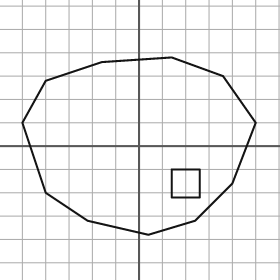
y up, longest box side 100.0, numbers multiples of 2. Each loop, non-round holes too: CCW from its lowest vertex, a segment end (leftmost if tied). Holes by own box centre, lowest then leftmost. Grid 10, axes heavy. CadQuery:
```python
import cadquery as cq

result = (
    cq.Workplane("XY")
    .moveTo(4.0, -38.0)
    .lineTo(24.0, -32.0)
    .lineTo(40.0, -16.0)
    .lineTo(50.0, 10.0)
    .lineTo(36.0, 30.0)
    .lineTo(14.0, 38.0)
    .lineTo(-16.0, 36.0)
    .lineTo(-40.0, 28.0)
    .lineTo(-50.0, 10.0)
    .lineTo(-40.0, -20.0)
    .lineTo(-22.0, -32.0)
    .close()
    .moveTo(14.0, -22.0)
    .lineTo(26.0, -22.0)
    .lineTo(26.0, -10.0)
    .lineTo(14.0, -10.0)
    .close()
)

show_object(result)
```